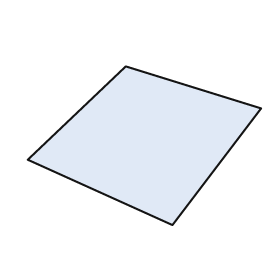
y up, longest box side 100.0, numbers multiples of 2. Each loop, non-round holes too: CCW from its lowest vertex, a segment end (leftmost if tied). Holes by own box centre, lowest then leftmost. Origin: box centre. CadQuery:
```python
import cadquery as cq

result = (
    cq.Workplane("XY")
    .moveTo(12.0, -34.0)
    .lineTo(50.0, 16.0)
    .lineTo(-8.0, 34.0)
    .lineTo(-50.0, -6.0)
    .close()
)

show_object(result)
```